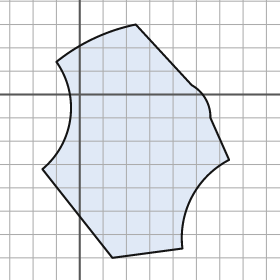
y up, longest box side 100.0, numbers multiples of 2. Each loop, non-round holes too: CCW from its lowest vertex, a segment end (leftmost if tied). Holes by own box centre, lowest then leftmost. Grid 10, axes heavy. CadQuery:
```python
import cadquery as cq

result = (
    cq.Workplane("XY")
    .moveTo(14.0, -70.0)
    .lineTo(44.0, -66.0)
    .threePointArc((48.0, -44.0), (64.0, -28.0))
    .lineTo(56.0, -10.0)
    .threePointArc((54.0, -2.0), (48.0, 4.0))
    .lineTo(24.0, 30.0)
    .threePointArc((6.0, 24.0), (-10.0, 14.0))
    .threePointArc((-4.0, -10.0), (-16.0, -32.0))
    .close()
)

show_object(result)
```